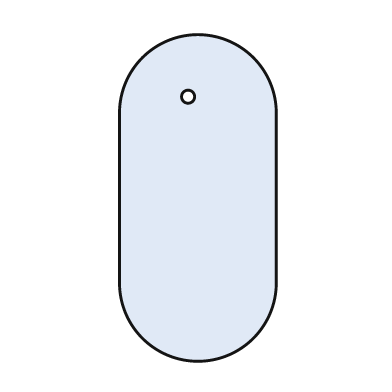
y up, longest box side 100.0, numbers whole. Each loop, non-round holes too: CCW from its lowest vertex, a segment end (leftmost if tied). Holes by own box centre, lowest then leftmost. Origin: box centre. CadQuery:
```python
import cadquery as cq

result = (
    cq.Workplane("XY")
    .moveTo(-24.0, -26.0)
    .threePointArc((0.0, -50.0), (24.0, -26.0))
    .lineTo(24.0, 26.0)
    .threePointArc((0.0, 50.0), (-24.0, 26.0))
    .close()
    .moveTo(-3.0, 31.0)
    .circle(2.0)
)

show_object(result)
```